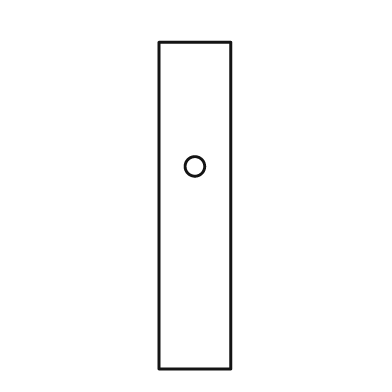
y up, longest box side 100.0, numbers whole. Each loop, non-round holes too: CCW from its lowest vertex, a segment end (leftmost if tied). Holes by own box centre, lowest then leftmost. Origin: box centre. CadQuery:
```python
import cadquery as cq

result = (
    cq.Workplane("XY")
    .moveTo(-11.0, -50.0)
    .lineTo(11.0, -50.0)
    .lineTo(11.0, 50.0)
    .lineTo(-11.0, 50.0)
    .close()
    .moveTo(0.0, 12.0)
    .circle(3.0)
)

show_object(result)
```